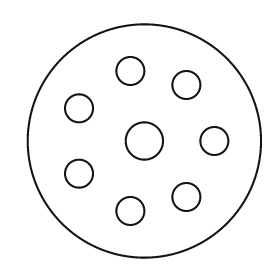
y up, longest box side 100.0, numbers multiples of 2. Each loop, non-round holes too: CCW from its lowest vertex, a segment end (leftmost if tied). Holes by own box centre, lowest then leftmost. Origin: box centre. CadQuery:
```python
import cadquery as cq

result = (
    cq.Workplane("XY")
    .moveTo(0.0, 0.0)
    .circle(50.0)
    .moveTo(-6.0, -30.0)
    .circle(6.0)
    .moveTo(18.0, -24.0)
    .circle(6.0)
    .moveTo(-28.0, -14.0)
    .circle(6.0)
    .moveTo(0.0, 0.0)
    .circle(8.0)
    .moveTo(30.0, 0.0)
    .circle(6.0)
    .moveTo(-28.0, 14.0)
    .circle(6.0)
    .moveTo(18.0, 24.0)
    .circle(6.0)
    .moveTo(-6.0, 30.0)
    .circle(6.0)
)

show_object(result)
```